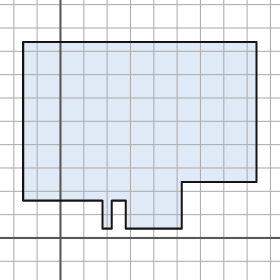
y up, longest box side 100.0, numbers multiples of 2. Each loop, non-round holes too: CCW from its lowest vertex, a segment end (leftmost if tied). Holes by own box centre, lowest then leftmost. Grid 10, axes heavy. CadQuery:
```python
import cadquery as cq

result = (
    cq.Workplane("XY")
    .moveTo(18.0, 4.0)
    .lineTo(22.0, 4.0)
    .lineTo(22.0, 16.0)
    .lineTo(28.0, 16.0)
    .lineTo(28.0, 4.0)
    .lineTo(52.0, 4.0)
    .lineTo(52.0, 24.0)
    .lineTo(84.0, 24.0)
    .lineTo(84.0, 84.0)
    .lineTo(-16.0, 84.0)
    .lineTo(-16.0, 16.0)
    .lineTo(18.0, 16.0)
    .close()
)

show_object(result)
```